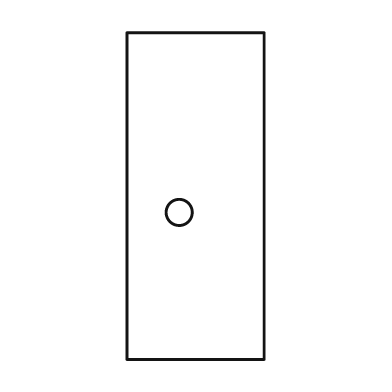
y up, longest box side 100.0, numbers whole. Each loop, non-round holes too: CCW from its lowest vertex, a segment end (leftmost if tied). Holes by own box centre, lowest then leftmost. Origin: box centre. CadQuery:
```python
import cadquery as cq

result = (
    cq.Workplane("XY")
    .moveTo(-21.0, -50.0)
    .lineTo(21.0, -50.0)
    .lineTo(21.0, 50.0)
    .lineTo(-21.0, 50.0)
    .close()
    .moveTo(-5.0, -5.0)
    .circle(4.0)
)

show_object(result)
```